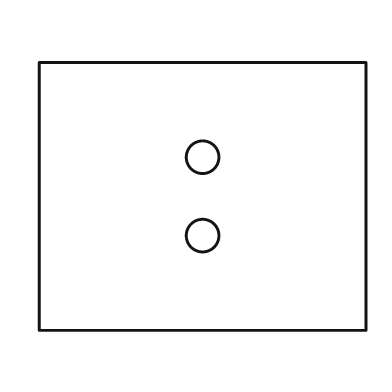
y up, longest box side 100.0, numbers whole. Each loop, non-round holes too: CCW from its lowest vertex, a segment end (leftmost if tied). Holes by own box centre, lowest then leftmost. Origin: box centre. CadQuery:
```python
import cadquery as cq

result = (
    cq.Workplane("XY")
    .moveTo(-50.0, -41.0)
    .lineTo(50.0, -41.0)
    .lineTo(50.0, 41.0)
    .lineTo(-50.0, 41.0)
    .close()
    .moveTo(0.0, -12.0)
    .circle(5.0)
    .moveTo(0.0, 12.0)
    .circle(5.0)
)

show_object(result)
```